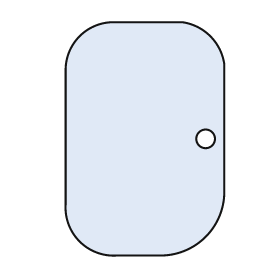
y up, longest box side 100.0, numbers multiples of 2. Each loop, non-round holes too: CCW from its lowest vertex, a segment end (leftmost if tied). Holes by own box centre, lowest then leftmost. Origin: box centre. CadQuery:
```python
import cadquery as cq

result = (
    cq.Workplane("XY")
    .moveTo(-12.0, -50.0)
    .lineTo(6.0, -50.0)
    .threePointArc((26.0, -42.0), (34.0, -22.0))
    .lineTo(34.0, 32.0)
    .threePointArc((28.0, 44.0), (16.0, 50.0))
    .lineTo(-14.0, 50.0)
    .threePointArc((-28.0, 44.0), (-34.0, 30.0))
    .lineTo(-34.0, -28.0)
    .threePointArc((-28.0, -44.0), (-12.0, -50.0))
    .close()
    .moveTo(26.0, 0.0)
    .circle(4.0)
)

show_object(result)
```